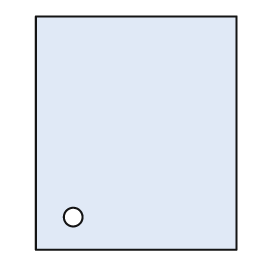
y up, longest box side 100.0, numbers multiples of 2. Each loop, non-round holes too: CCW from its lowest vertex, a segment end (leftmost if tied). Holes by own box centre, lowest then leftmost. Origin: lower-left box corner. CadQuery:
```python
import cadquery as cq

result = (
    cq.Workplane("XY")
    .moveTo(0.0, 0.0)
    .lineTo(86.0, 0.0)
    .lineTo(86.0, 100.0)
    .lineTo(0.0, 100.0)
    .close()
    .moveTo(16.0, 14.0)
    .circle(4.0)
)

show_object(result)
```